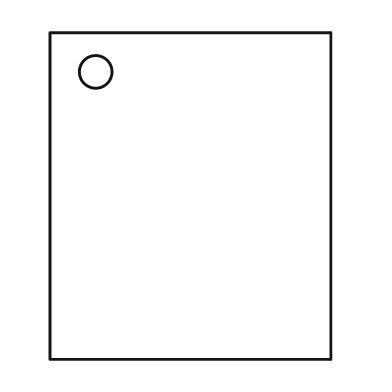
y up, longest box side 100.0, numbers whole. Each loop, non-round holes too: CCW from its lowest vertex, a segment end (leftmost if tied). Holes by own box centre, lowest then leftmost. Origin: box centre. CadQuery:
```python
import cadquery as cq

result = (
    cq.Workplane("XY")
    .moveTo(-43.0, -50.0)
    .lineTo(43.0, -50.0)
    .lineTo(43.0, 50.0)
    .lineTo(-43.0, 50.0)
    .close()
    .moveTo(-29.0, 38.0)
    .circle(5.0)
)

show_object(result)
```